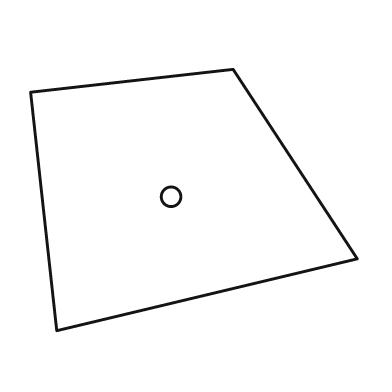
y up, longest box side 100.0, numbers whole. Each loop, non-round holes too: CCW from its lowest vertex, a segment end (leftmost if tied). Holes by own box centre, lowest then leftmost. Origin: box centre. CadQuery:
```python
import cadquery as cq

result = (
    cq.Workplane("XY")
    .moveTo(-42.0, -40.0)
    .lineTo(50.0, -18.0)
    .lineTo(12.0, 40.0)
    .lineTo(-50.0, 33.0)
    .close()
    .moveTo(-7.0, 1.0)
    .circle(3.0)
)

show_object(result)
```